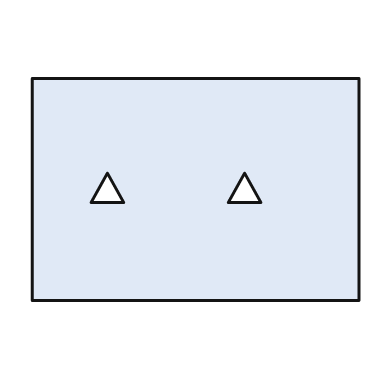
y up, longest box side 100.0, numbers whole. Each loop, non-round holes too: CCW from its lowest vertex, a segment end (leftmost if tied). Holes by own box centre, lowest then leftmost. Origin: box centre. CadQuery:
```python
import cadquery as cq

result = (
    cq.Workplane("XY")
    .moveTo(-50.0, -34.0)
    .lineTo(50.0, -34.0)
    .lineTo(50.0, 34.0)
    .lineTo(-50.0, 34.0)
    .close()
    .moveTo(-32.0, -4.0)
    .lineTo(-22.0, -4.0)
    .lineTo(-27.0, 5.0)
    .close()
    .moveTo(10.0, -4.0)
    .lineTo(20.0, -4.0)
    .lineTo(15.0, 5.0)
    .close()
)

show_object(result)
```